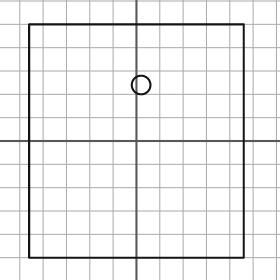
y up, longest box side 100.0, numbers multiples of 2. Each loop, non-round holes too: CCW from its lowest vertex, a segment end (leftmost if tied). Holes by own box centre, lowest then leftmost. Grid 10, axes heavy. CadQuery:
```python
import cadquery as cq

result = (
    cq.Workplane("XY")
    .moveTo(-46.0, -50.0)
    .lineTo(46.0, -50.0)
    .lineTo(46.0, 50.0)
    .lineTo(-46.0, 50.0)
    .close()
    .moveTo(2.0, 24.0)
    .circle(4.0)
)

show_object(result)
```